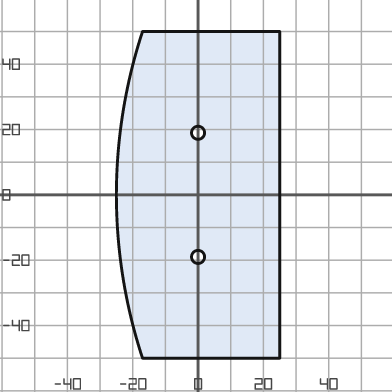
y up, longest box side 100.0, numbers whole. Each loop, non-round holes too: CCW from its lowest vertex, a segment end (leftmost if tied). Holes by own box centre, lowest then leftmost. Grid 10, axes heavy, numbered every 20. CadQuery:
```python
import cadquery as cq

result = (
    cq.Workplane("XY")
    .moveTo(-17.0, -50.0)
    .lineTo(25.0, -50.0)
    .lineTo(25.0, 50.0)
    .lineTo(-17.0, 50.0)
    .threePointArc((-25.0, 0.0), (-17.0, -50.0))
    .close()
    .moveTo(0.0, -19.0)
    .circle(2.0)
    .moveTo(0.0, 19.0)
    .circle(2.0)
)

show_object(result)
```